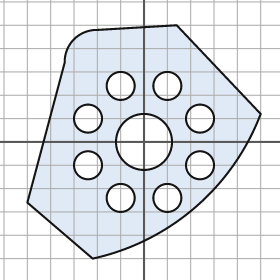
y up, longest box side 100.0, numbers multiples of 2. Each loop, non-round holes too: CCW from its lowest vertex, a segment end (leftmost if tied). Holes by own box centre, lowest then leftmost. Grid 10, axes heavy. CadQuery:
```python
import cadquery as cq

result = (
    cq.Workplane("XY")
    .moveTo(-22.0, -50.0)
    .threePointArc((22.0, -28.0), (50.0, 12.0))
    .lineTo(14.0, 50.0)
    .lineTo(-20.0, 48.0)
    .threePointArc((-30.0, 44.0), (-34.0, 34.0))
    .lineTo(-50.0, -26.0)
    .close()
    .moveTo(-10.0, -24.0)
    .circle(6.0)
    .moveTo(10.0, -24.0)
    .circle(6.0)
    .moveTo(-24.0, -10.0)
    .circle(6.0)
    .moveTo(24.0, -10.0)
    .circle(6.0)
    .moveTo(0.0, 0.0)
    .circle(12.0)
    .moveTo(-24.0, 10.0)
    .circle(6.0)
    .moveTo(24.0, 10.0)
    .circle(6.0)
    .moveTo(-10.0, 24.0)
    .circle(6.0)
    .moveTo(10.0, 24.0)
    .circle(6.0)
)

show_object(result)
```